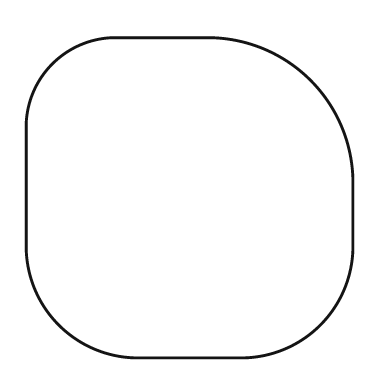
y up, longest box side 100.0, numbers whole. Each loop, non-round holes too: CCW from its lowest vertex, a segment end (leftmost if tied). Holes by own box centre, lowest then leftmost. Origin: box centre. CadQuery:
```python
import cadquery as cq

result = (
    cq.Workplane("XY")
    .moveTo(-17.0, -49.0)
    .lineTo(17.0, -49.0)
    .threePointArc((40.0, -39.0), (50.0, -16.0))
    .lineTo(50.0, 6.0)
    .threePointArc((37.0, 36.0), (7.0, 49.0))
    .lineTo(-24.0, 49.0)
    .threePointArc((-42.0, 41.0), (-50.0, 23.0))
    .lineTo(-50.0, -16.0)
    .threePointArc((-40.0, -39.0), (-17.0, -49.0))
    .close()
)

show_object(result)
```